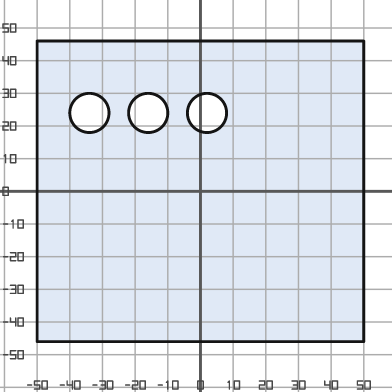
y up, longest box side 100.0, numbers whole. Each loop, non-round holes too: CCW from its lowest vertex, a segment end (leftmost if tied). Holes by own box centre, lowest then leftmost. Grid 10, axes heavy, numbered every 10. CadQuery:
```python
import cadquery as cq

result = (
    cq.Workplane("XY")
    .moveTo(-50.0, -46.0)
    .lineTo(50.0, -46.0)
    .lineTo(50.0, 46.0)
    .lineTo(-50.0, 46.0)
    .close()
    .moveTo(-34.0, 24.0)
    .circle(6.0)
    .moveTo(-16.0, 24.0)
    .circle(6.0)
    .moveTo(2.0, 24.0)
    .circle(6.0)
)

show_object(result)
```